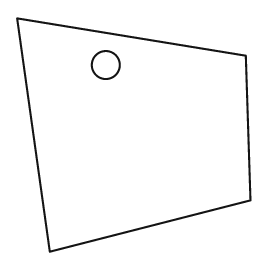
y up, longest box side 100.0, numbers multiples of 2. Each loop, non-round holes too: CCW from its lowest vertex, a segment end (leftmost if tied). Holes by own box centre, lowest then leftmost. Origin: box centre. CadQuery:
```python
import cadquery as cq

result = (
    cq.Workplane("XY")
    .moveTo(-36.0, -50.0)
    .lineTo(50.0, -28.0)
    .lineTo(48.0, 34.0)
    .lineTo(-50.0, 50.0)
    .close()
    .moveTo(-12.0, 30.0)
    .circle(6.0)
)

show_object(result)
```